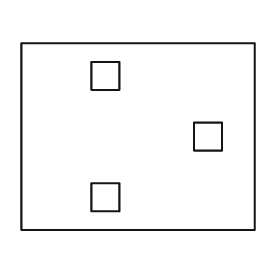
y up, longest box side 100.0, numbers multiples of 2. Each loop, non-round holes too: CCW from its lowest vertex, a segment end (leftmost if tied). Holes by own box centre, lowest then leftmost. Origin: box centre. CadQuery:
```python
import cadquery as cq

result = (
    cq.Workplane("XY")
    .moveTo(-50.0, -40.0)
    .lineTo(50.0, -40.0)
    .lineTo(50.0, 40.0)
    .lineTo(-50.0, 40.0)
    .close()
    .moveTo(-20.0, -32.0)
    .lineTo(-8.0, -32.0)
    .lineTo(-8.0, -20.0)
    .lineTo(-20.0, -20.0)
    .close()
    .moveTo(24.0, -6.0)
    .lineTo(36.0, -6.0)
    .lineTo(36.0, 6.0)
    .lineTo(24.0, 6.0)
    .close()
    .moveTo(-20.0, 20.0)
    .lineTo(-8.0, 20.0)
    .lineTo(-8.0, 32.0)
    .lineTo(-20.0, 32.0)
    .close()
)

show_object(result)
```